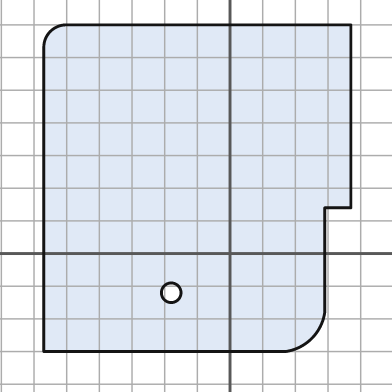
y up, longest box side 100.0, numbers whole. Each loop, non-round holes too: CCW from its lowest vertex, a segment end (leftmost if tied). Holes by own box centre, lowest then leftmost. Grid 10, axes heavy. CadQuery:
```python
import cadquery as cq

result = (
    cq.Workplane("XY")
    .moveTo(-57.0, -30.0)
    .lineTo(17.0, -30.0)
    .threePointArc((25.0, -26.0), (29.0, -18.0))
    .lineTo(29.0, 14.0)
    .lineTo(37.0, 14.0)
    .lineTo(37.0, 70.0)
    .lineTo(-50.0, 70.0)
    .threePointArc((-55.0, 68.0), (-57.0, 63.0))
    .close()
    .moveTo(-18.0, -12.0)
    .circle(3.0)
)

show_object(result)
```